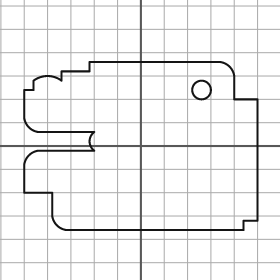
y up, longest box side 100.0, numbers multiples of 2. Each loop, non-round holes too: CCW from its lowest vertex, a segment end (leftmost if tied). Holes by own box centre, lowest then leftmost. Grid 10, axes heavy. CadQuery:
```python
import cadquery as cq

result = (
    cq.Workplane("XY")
    .moveTo(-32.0, -36.0)
    .lineTo(44.0, -36.0)
    .lineTo(44.0, -32.0)
    .lineTo(50.0, -32.0)
    .lineTo(50.0, 20.0)
    .lineTo(40.0, 20.0)
    .lineTo(40.0, 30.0)
    .threePointArc((38.0, 34.0), (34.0, 36.0))
    .lineTo(-22.0, 36.0)
    .lineTo(-22.0, 32.0)
    .lineTo(-34.0, 32.0)
    .lineTo(-34.0, 28.0)
    .threePointArc((-40.0, 30.0), (-46.0, 28.0))
    .lineTo(-46.0, 24.0)
    .lineTo(-50.0, 24.0)
    .lineTo(-50.0, 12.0)
    .threePointArc((-48.0, 8.0), (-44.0, 6.0))
    .lineTo(-20.0, 6.0)
    .threePointArc((-22.0, 2.0), (-20.0, -2.0))
    .lineTo(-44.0, -2.0)
    .threePointArc((-48.0, -4.0), (-50.0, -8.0))
    .lineTo(-50.0, -20.0)
    .lineTo(-38.0, -20.0)
    .lineTo(-38.0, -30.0)
    .threePointArc((-36.0, -34.0), (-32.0, -36.0))
    .close()
    .moveTo(26.0, 24.0)
    .circle(4.0)
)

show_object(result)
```